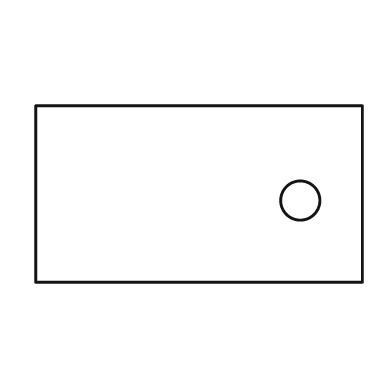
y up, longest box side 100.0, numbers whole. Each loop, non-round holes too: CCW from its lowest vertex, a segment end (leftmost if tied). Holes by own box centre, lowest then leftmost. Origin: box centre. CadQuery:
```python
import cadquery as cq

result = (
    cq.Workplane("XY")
    .moveTo(-50.0, -27.0)
    .lineTo(50.0, -27.0)
    .lineTo(50.0, 27.0)
    .lineTo(-50.0, 27.0)
    .close()
    .moveTo(31.0, -2.0)
    .circle(6.0)
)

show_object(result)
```